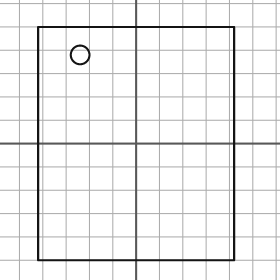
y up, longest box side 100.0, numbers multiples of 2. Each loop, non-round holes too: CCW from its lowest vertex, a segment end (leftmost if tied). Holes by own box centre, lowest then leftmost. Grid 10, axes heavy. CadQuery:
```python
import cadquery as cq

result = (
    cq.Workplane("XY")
    .moveTo(-42.0, -50.0)
    .lineTo(42.0, -50.0)
    .lineTo(42.0, 50.0)
    .lineTo(-42.0, 50.0)
    .close()
    .moveTo(-24.0, 38.0)
    .circle(4.0)
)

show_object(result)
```